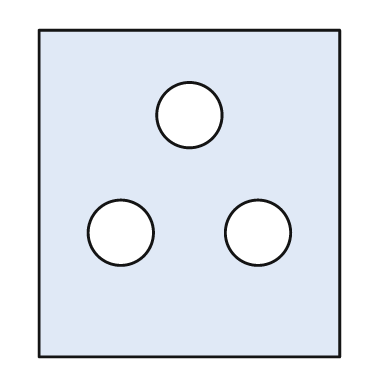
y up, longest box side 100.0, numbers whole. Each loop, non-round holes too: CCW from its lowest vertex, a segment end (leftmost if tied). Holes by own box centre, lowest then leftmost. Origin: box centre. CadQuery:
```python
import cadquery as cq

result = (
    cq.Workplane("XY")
    .moveTo(-46.0, -50.0)
    .lineTo(46.0, -50.0)
    .lineTo(46.0, 50.0)
    .lineTo(-46.0, 50.0)
    .close()
    .moveTo(-21.0, -12.0)
    .circle(10.0)
    .moveTo(21.0, -12.0)
    .circle(10.0)
    .moveTo(0.0, 24.0)
    .circle(10.0)
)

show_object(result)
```